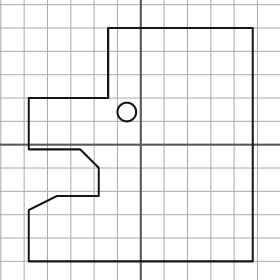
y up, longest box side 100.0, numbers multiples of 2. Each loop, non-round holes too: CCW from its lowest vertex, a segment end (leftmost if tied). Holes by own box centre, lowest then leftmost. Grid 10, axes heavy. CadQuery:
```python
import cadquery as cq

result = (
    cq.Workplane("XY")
    .moveTo(-48.0, -50.0)
    .lineTo(48.0, -50.0)
    .lineTo(48.0, 50.0)
    .lineTo(-14.0, 50.0)
    .lineTo(-14.0, 20.0)
    .lineTo(-48.0, 20.0)
    .lineTo(-48.0, -2.0)
    .lineTo(-26.0, -2.0)
    .lineTo(-18.0, -10.0)
    .lineTo(-18.0, -22.0)
    .lineTo(-36.0, -22.0)
    .lineTo(-48.0, -28.0)
    .close()
    .moveTo(-6.0, 14.0)
    .circle(4.0)
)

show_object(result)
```